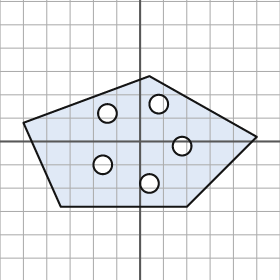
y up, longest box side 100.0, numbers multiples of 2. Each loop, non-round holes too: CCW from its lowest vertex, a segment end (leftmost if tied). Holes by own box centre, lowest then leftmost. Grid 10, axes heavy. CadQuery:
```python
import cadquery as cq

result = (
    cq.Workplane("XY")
    .moveTo(-34.0, -28.0)
    .lineTo(20.0, -28.0)
    .lineTo(50.0, 2.0)
    .lineTo(4.0, 28.0)
    .lineTo(-50.0, 8.0)
    .close()
    .moveTo(4.0, -18.0)
    .circle(4.0)
    .moveTo(-16.0, -10.0)
    .circle(4.0)
    .moveTo(18.0, -2.0)
    .circle(4.0)
    .moveTo(-14.0, 12.0)
    .circle(4.0)
    .moveTo(8.0, 16.0)
    .circle(4.0)
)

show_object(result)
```